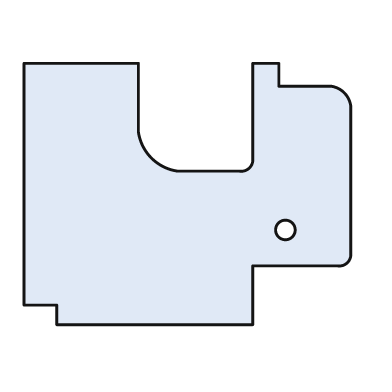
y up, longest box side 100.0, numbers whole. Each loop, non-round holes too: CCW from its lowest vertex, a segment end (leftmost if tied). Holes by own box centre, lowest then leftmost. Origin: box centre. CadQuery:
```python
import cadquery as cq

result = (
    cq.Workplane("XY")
    .moveTo(-40.0, -40.0)
    .lineTo(20.0, -40.0)
    .lineTo(20.0, -22.0)
    .lineTo(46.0, -22.0)
    .threePointArc((49.0, -21.0), (50.0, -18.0))
    .lineTo(50.0, 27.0)
    .threePointArc((48.0, 31.0), (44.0, 33.0))
    .lineTo(28.0, 33.0)
    .lineTo(28.0, 40.0)
    .lineTo(20.0, 40.0)
    .lineTo(20.0, 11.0)
    .threePointArc((19.0, 8.0), (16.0, 7.0))
    .lineTo(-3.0, 7.0)
    .threePointArc((-11.0, 11.0), (-15.0, 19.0))
    .lineTo(-15.0, 40.0)
    .lineTo(-50.0, 40.0)
    .lineTo(-50.0, -34.0)
    .lineTo(-40.0, -34.0)
    .close()
    .moveTo(30.0, -11.0)
    .circle(3.0)
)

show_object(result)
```